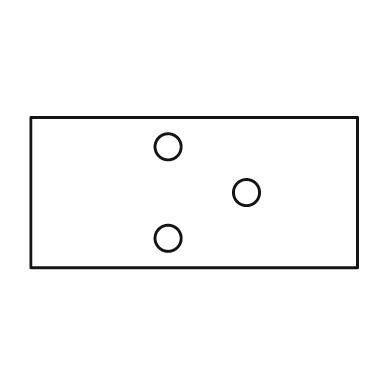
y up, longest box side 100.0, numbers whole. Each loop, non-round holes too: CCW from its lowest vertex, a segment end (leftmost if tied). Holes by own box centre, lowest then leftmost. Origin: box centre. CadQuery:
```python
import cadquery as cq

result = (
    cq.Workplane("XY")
    .moveTo(-50.0, -23.0)
    .lineTo(50.0, -23.0)
    .lineTo(50.0, 23.0)
    .lineTo(-50.0, 23.0)
    .close()
    .moveTo(-8.0, -14.0)
    .circle(4.0)
    .moveTo(16.0, 0.0)
    .circle(4.0)
    .moveTo(-8.0, 14.0)
    .circle(4.0)
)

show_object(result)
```